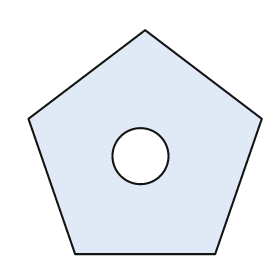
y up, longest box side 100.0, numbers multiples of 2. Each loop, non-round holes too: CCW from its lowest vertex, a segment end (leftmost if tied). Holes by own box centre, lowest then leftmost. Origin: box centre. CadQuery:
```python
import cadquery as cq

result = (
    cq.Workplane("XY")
    .moveTo(-30.0, -48.0)
    .lineTo(30.0, -48.0)
    .lineTo(50.0, 10.0)
    .lineTo(0.0, 48.0)
    .lineTo(-50.0, 10.0)
    .close()
    .moveTo(-2.0, -6.0)
    .circle(12.0)
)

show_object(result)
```